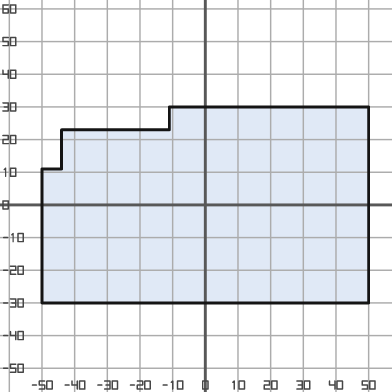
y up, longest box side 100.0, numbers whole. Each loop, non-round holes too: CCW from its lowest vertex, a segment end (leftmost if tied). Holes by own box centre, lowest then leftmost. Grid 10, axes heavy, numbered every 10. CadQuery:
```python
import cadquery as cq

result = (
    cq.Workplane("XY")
    .moveTo(-50.0, -30.0)
    .lineTo(50.0, -30.0)
    .lineTo(50.0, 30.0)
    .lineTo(-11.0, 30.0)
    .lineTo(-11.0, 23.0)
    .lineTo(-44.0, 23.0)
    .lineTo(-44.0, 11.0)
    .lineTo(-50.0, 11.0)
    .close()
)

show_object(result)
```